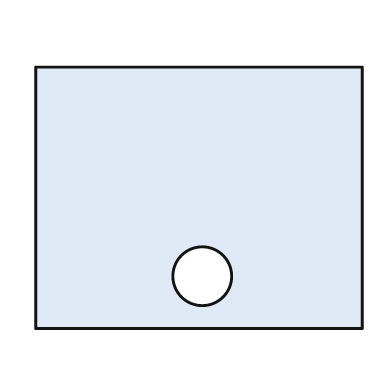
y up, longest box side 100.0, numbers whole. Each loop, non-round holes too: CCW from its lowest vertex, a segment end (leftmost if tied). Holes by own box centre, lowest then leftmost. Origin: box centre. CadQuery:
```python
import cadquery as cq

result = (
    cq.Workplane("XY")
    .moveTo(-50.0, -40.0)
    .lineTo(50.0, -40.0)
    .lineTo(50.0, 40.0)
    .lineTo(-50.0, 40.0)
    .close()
    .moveTo(1.0, -24.0)
    .circle(9.0)
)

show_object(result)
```